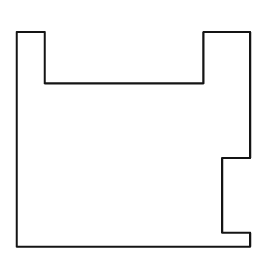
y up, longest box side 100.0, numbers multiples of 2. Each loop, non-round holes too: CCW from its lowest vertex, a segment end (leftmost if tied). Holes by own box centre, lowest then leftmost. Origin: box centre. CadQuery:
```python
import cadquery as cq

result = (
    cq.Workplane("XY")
    .moveTo(-50.0, -46.0)
    .lineTo(50.0, -46.0)
    .lineTo(50.0, -40.0)
    .lineTo(38.0, -40.0)
    .lineTo(38.0, -8.0)
    .lineTo(50.0, -8.0)
    .lineTo(50.0, 46.0)
    .lineTo(30.0, 46.0)
    .lineTo(30.0, 24.0)
    .lineTo(-38.0, 24.0)
    .lineTo(-38.0, 46.0)
    .lineTo(-50.0, 46.0)
    .close()
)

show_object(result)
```